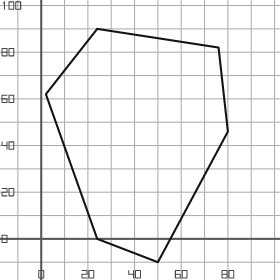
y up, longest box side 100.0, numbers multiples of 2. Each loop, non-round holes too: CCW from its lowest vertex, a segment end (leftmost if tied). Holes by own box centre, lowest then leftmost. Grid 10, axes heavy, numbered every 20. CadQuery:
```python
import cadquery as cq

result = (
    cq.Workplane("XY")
    .moveTo(50.0, -10.0)
    .lineTo(80.0, 46.0)
    .lineTo(76.0, 82.0)
    .lineTo(24.0, 90.0)
    .lineTo(2.0, 62.0)
    .lineTo(24.0, 0.0)
    .close()
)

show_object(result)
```